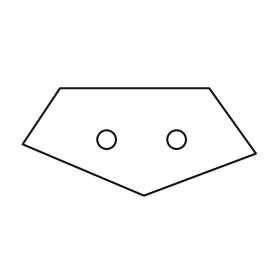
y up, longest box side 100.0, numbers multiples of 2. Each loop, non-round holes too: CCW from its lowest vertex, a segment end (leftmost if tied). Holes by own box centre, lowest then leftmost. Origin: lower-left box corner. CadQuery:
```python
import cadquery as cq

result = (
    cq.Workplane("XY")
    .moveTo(52.0, 0.0)
    .lineTo(100.0, 18.0)
    .lineTo(80.0, 46.0)
    .lineTo(16.0, 46.0)
    .lineTo(0.0, 22.0)
    .close()
    .moveTo(36.0, 24.0)
    .circle(4.0)
    .moveTo(66.0, 24.0)
    .circle(4.0)
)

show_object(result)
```